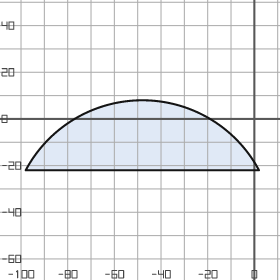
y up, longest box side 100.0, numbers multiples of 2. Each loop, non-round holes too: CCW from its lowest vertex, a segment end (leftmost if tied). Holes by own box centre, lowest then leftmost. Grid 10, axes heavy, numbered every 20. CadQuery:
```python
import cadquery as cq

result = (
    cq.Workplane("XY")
    .moveTo(-98.0, -22.0)
    .lineTo(2.0, -22.0)
    .threePointArc((-48.0, 8.0), (-98.0, -22.0))
    .close()
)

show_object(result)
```